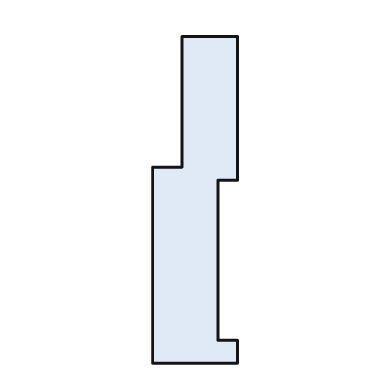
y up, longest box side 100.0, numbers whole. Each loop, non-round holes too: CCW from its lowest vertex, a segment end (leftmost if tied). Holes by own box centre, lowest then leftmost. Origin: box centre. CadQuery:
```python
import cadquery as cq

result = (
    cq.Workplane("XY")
    .moveTo(-13.0, -50.0)
    .lineTo(13.0, -50.0)
    .lineTo(13.0, -43.0)
    .lineTo(7.0, -43.0)
    .lineTo(7.0, 6.0)
    .lineTo(13.0, 6.0)
    .lineTo(13.0, 50.0)
    .lineTo(-4.0, 50.0)
    .lineTo(-4.0, 10.0)
    .lineTo(-13.0, 10.0)
    .close()
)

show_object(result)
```